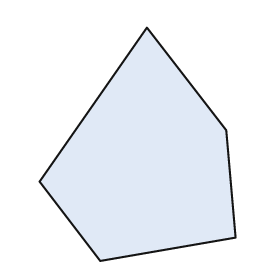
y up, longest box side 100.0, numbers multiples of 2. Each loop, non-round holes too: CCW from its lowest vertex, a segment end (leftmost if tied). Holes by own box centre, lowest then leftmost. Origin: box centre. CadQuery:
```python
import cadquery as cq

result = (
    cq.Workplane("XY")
    .moveTo(-16.0, -50.0)
    .lineTo(42.0, -40.0)
    .lineTo(38.0, 6.0)
    .lineTo(4.0, 50.0)
    .lineTo(-42.0, -16.0)
    .close()
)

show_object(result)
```